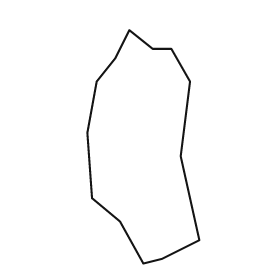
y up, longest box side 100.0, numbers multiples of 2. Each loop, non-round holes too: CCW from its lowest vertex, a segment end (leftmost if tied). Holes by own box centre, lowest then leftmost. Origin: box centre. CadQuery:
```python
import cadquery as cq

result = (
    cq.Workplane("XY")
    .moveTo(0.0, -50.0)
    .lineTo(8.0, -48.0)
    .lineTo(24.0, -40.0)
    .lineTo(16.0, -4.0)
    .lineTo(20.0, 28.0)
    .lineTo(12.0, 42.0)
    .lineTo(4.0, 42.0)
    .lineTo(-6.0, 50.0)
    .lineTo(-12.0, 38.0)
    .lineTo(-20.0, 28.0)
    .lineTo(-24.0, 6.0)
    .lineTo(-22.0, -22.0)
    .lineTo(-10.0, -32.0)
    .close()
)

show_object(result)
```